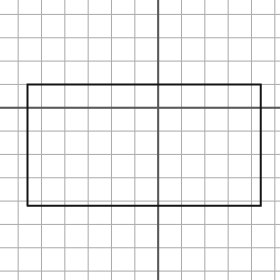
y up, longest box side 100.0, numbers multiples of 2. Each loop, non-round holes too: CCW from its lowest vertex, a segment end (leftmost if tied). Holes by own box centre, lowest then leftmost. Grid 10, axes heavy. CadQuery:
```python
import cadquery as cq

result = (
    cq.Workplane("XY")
    .moveTo(-56.0, -42.0)
    .lineTo(44.0, -42.0)
    .lineTo(44.0, 10.0)
    .lineTo(-56.0, 10.0)
    .close()
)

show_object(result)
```